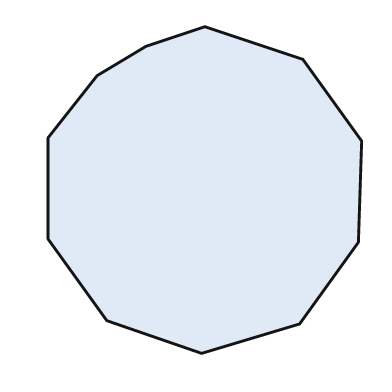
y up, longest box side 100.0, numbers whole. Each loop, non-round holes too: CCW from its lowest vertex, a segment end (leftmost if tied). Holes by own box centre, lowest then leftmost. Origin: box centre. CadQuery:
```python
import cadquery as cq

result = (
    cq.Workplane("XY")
    .moveTo(-1.0, -50.0)
    .lineTo(29.0, -41.0)
    .lineTo(47.0, -16.0)
    .lineTo(48.0, 15.0)
    .lineTo(30.0, 40.0)
    .lineTo(0.0, 50.0)
    .lineTo(-18.0, 44.0)
    .lineTo(-33.0, 35.0)
    .lineTo(-48.0, 16.0)
    .lineTo(-48.0, -15.0)
    .lineTo(-30.0, -40.0)
    .close()
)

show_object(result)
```